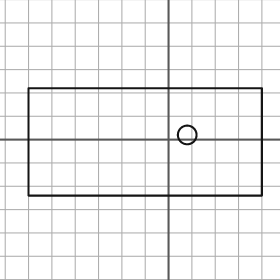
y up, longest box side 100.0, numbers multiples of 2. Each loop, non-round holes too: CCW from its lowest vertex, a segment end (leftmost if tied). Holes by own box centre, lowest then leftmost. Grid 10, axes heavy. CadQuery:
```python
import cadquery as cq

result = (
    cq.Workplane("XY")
    .moveTo(-60.0, -24.0)
    .lineTo(40.0, -24.0)
    .lineTo(40.0, 22.0)
    .lineTo(-60.0, 22.0)
    .close()
    .moveTo(8.0, 2.0)
    .circle(4.0)
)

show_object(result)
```